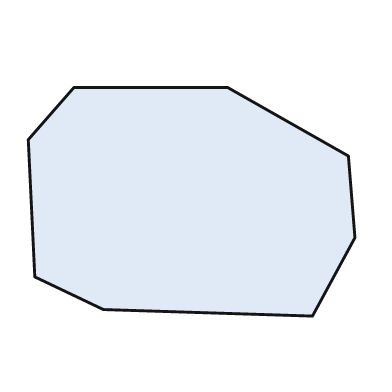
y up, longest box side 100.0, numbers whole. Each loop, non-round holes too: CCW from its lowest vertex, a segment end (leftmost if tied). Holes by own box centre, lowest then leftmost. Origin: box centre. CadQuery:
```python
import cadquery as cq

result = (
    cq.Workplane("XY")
    .moveTo(37.0, -35.0)
    .lineTo(50.0, -11.0)
    .lineTo(48.0, 14.0)
    .lineTo(11.0, 35.0)
    .lineTo(-36.0, 35.0)
    .lineTo(-50.0, 19.0)
    .lineTo(-48.0, -23.0)
    .lineTo(-27.0, -33.0)
    .close()
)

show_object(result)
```